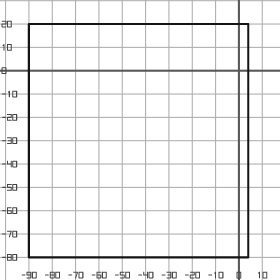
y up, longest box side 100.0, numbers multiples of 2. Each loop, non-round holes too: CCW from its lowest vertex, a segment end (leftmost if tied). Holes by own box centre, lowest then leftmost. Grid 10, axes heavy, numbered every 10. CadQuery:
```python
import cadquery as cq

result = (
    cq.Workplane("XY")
    .moveTo(-90.0, -80.0)
    .lineTo(4.0, -80.0)
    .lineTo(4.0, 20.0)
    .lineTo(-90.0, 20.0)
    .close()
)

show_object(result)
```